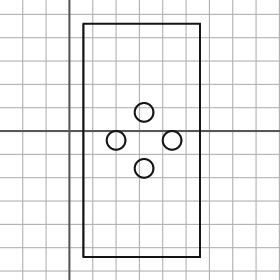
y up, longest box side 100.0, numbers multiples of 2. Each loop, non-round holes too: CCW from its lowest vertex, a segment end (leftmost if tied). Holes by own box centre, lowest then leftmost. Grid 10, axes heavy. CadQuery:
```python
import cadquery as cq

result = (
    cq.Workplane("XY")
    .moveTo(6.0, -54.0)
    .lineTo(56.0, -54.0)
    .lineTo(56.0, 46.0)
    .lineTo(6.0, 46.0)
    .close()
    .moveTo(32.0, -16.0)
    .circle(4.0)
    .moveTo(20.0, -4.0)
    .circle(4.0)
    .moveTo(44.0, -4.0)
    .circle(4.0)
    .moveTo(32.0, 8.0)
    .circle(4.0)
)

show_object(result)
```